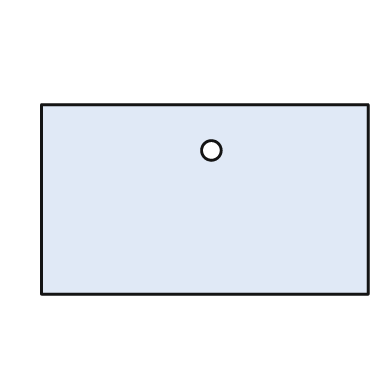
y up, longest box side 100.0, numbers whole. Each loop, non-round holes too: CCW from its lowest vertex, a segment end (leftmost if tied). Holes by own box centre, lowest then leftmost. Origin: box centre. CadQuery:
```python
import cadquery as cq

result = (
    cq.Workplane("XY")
    .moveTo(-50.0, -29.0)
    .lineTo(50.0, -29.0)
    .lineTo(50.0, 29.0)
    .lineTo(-50.0, 29.0)
    .close()
    .moveTo(2.0, 15.0)
    .circle(3.0)
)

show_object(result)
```